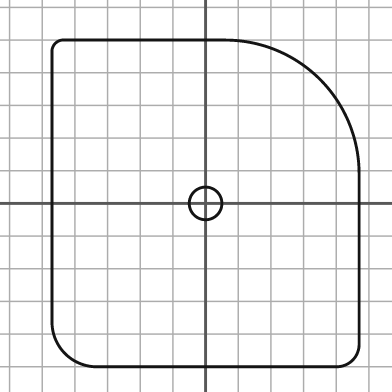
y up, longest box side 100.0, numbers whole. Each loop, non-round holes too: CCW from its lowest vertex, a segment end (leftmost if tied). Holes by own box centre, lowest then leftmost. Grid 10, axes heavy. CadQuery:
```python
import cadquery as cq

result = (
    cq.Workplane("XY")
    .moveTo(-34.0, -50.0)
    .lineTo(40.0, -50.0)
    .threePointArc((45.0, -48.0), (47.0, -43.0))
    .lineTo(47.0, 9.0)
    .threePointArc((35.0, 38.0), (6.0, 50.0))
    .lineTo(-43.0, 50.0)
    .threePointArc((-46.0, 49.0), (-47.0, 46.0))
    .lineTo(-47.0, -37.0)
    .threePointArc((-43.0, -46.0), (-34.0, -50.0))
    .close()
    .moveTo(0.0, 0.0)
    .circle(5.0)
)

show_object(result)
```